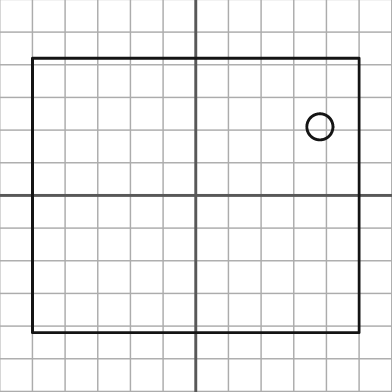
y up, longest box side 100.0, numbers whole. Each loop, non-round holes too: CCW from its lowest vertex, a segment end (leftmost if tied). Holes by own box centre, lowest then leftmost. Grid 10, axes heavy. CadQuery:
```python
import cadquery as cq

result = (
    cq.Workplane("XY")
    .moveTo(-50.0, -42.0)
    .lineTo(50.0, -42.0)
    .lineTo(50.0, 42.0)
    .lineTo(-50.0, 42.0)
    .close()
    .moveTo(38.0, 21.0)
    .circle(4.0)
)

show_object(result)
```